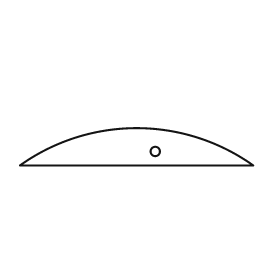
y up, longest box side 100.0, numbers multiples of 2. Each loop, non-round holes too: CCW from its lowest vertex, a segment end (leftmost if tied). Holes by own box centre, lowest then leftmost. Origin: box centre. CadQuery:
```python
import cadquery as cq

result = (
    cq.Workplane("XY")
    .moveTo(-50.0, -8.0)
    .lineTo(50.0, -8.0)
    .threePointArc((0.0, 8.0), (-50.0, -8.0))
    .close()
    .moveTo(8.0, -2.0)
    .circle(2.0)
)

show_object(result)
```